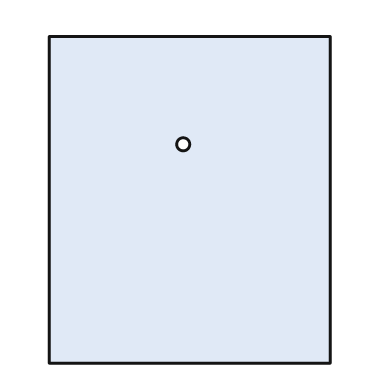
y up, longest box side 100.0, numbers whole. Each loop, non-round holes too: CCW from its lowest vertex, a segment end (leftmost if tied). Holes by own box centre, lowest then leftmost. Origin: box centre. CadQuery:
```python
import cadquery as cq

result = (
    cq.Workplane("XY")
    .moveTo(-43.0, -50.0)
    .lineTo(43.0, -50.0)
    .lineTo(43.0, 50.0)
    .lineTo(-43.0, 50.0)
    .close()
    .moveTo(-2.0, 17.0)
    .circle(2.0)
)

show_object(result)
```